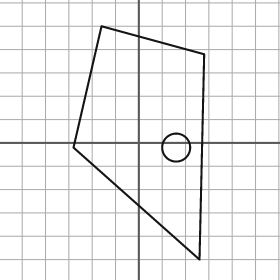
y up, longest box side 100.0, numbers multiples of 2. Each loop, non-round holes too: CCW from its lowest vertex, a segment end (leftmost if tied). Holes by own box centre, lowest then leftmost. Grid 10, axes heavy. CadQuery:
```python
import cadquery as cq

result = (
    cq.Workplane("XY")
    .moveTo(26.0, -50.0)
    .lineTo(28.0, 38.0)
    .lineTo(-16.0, 50.0)
    .lineTo(-28.0, -2.0)
    .close()
    .moveTo(16.0, -2.0)
    .circle(6.0)
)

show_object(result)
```